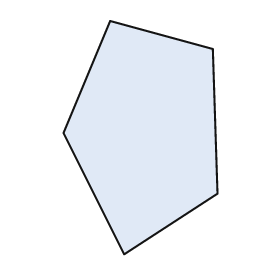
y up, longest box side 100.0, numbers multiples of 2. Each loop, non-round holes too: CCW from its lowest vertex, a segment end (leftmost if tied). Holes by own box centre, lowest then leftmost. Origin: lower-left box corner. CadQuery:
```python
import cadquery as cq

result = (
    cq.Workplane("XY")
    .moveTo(26.0, 0.0)
    .lineTo(66.0, 26.0)
    .lineTo(64.0, 88.0)
    .lineTo(20.0, 100.0)
    .lineTo(0.0, 52.0)
    .close()
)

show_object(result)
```